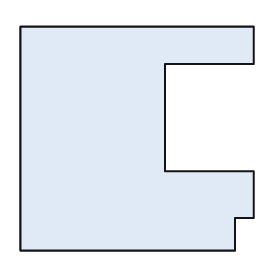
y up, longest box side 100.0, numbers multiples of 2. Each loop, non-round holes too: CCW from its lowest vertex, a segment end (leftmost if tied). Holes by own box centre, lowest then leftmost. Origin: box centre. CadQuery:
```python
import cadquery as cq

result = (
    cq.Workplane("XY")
    .moveTo(-50.0, -48.0)
    .lineTo(42.0, -48.0)
    .lineTo(42.0, -34.0)
    .lineTo(50.0, -34.0)
    .lineTo(50.0, -14.0)
    .lineTo(12.0, -14.0)
    .lineTo(12.0, 32.0)
    .lineTo(50.0, 32.0)
    .lineTo(50.0, 48.0)
    .lineTo(-50.0, 48.0)
    .close()
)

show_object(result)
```